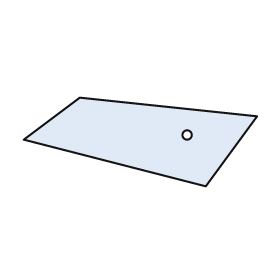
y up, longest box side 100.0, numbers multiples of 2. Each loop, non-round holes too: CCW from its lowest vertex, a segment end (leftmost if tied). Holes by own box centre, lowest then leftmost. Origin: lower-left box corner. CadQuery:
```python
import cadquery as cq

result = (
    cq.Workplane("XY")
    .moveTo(78.0, 0.0)
    .lineTo(100.0, 30.0)
    .lineTo(24.0, 38.0)
    .lineTo(0.0, 20.0)
    .close()
    .moveTo(70.0, 22.0)
    .circle(2.0)
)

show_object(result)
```